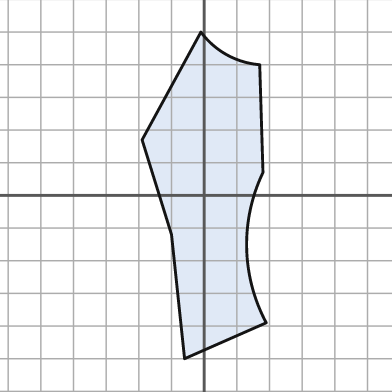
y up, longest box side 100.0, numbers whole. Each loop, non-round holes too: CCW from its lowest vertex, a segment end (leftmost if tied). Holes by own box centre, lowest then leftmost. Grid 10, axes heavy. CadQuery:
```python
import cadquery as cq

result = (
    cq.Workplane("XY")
    .moveTo(-6.0, -50.0)
    .lineTo(19.0, -39.0)
    .threePointArc((13.0, -16.0), (18.0, 7.0))
    .lineTo(17.0, 40.0)
    .threePointArc((7.0, 43.0), (-1.0, 50.0))
    .lineTo(-19.0, 17.0)
    .lineTo(-10.0, -12.0)
    .close()
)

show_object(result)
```